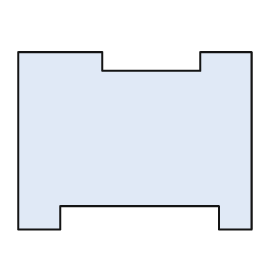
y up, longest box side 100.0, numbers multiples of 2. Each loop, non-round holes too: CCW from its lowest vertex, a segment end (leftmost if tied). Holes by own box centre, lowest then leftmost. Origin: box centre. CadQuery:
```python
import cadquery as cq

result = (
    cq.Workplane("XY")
    .moveTo(-50.0, -38.0)
    .lineTo(-32.0, -38.0)
    .lineTo(-32.0, -28.0)
    .lineTo(36.0, -28.0)
    .lineTo(36.0, -38.0)
    .lineTo(50.0, -38.0)
    .lineTo(50.0, 38.0)
    .lineTo(28.0, 38.0)
    .lineTo(28.0, 30.0)
    .lineTo(-14.0, 30.0)
    .lineTo(-14.0, 38.0)
    .lineTo(-50.0, 38.0)
    .close()
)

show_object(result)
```